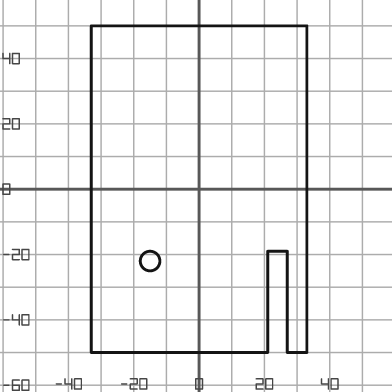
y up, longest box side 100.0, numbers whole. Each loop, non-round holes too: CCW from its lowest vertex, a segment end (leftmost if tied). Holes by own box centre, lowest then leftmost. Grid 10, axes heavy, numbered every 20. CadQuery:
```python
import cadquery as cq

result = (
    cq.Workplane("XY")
    .moveTo(-33.0, -50.0)
    .lineTo(21.0, -50.0)
    .lineTo(21.0, -19.0)
    .lineTo(27.0, -19.0)
    .lineTo(27.0, -50.0)
    .lineTo(33.0, -50.0)
    .lineTo(33.0, 50.0)
    .lineTo(-33.0, 50.0)
    .close()
    .moveTo(-15.0, -22.0)
    .circle(3.0)
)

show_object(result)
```